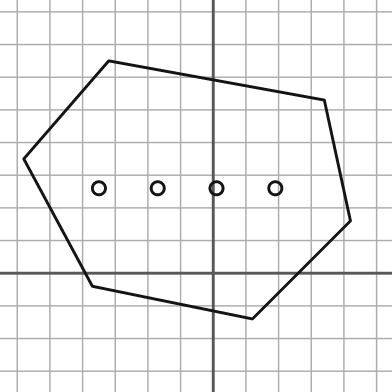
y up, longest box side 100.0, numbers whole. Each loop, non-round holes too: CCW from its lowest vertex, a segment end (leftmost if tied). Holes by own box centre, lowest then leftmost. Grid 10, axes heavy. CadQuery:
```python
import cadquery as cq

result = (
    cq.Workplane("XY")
    .moveTo(12.0, -14.0)
    .lineTo(42.0, 16.0)
    .lineTo(34.0, 53.0)
    .lineTo(-32.0, 65.0)
    .lineTo(-58.0, 35.0)
    .lineTo(-37.0, -4.0)
    .close()
    .moveTo(-35.0, 26.0)
    .circle(2.0)
    .moveTo(-17.0, 26.0)
    .circle(2.0)
    .moveTo(1.0, 26.0)
    .circle(2.0)
    .moveTo(19.0, 26.0)
    .circle(2.0)
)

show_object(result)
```